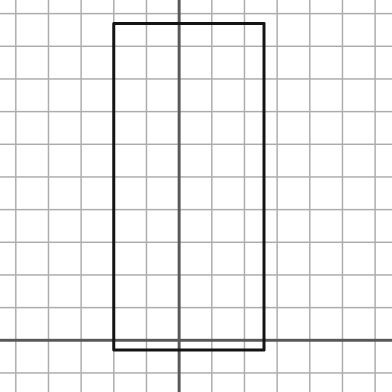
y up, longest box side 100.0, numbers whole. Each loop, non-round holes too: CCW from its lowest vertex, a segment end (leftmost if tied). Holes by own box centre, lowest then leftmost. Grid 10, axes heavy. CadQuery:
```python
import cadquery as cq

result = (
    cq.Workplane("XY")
    .moveTo(-20.0, -3.0)
    .lineTo(26.0, -3.0)
    .lineTo(26.0, 97.0)
    .lineTo(-20.0, 97.0)
    .close()
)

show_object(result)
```